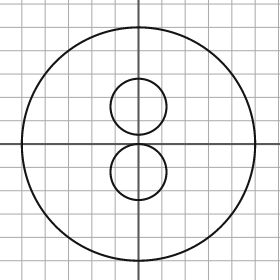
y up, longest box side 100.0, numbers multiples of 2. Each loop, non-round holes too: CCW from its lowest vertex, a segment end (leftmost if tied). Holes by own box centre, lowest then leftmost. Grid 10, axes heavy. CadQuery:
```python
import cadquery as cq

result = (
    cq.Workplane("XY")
    .moveTo(0.0, 0.0)
    .circle(50.0)
    .moveTo(0.0, -12.0)
    .circle(12.0)
    .moveTo(0.0, 16.0)
    .circle(12.0)
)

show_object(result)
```